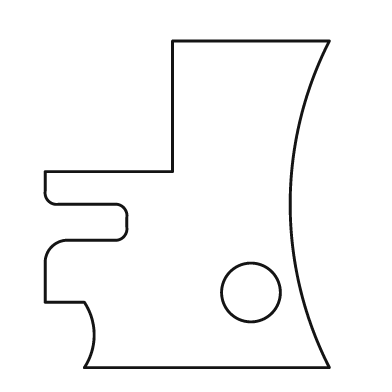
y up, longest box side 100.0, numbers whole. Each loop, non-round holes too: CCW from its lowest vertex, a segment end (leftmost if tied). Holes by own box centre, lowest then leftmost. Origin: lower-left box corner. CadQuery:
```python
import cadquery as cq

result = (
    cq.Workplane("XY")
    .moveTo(12.0, 0.0)
    .lineTo(87.0, 0.0)
    .threePointArc((75.0, 50.0), (87.0, 100.0))
    .lineTo(39.0, 100.0)
    .lineTo(39.0, 60.0)
    .lineTo(0.0, 60.0)
    .lineTo(0.0, 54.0)
    .threePointArc((1.0, 51.0), (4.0, 50.0))
    .lineTo(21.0, 50.0)
    .threePointArc((24.0, 49.0), (25.0, 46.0))
    .lineTo(25.0, 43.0)
    .threePointArc((24.0, 40.0), (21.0, 39.0))
    .lineTo(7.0, 39.0)
    .threePointArc((2.0, 37.0), (0.0, 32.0))
    .lineTo(0.0, 20.0)
    .lineTo(12.0, 20.0)
    .threePointArc((15.0, 10.0), (12.0, 0.0))
    .close()
    .moveTo(63.0, 23.0)
    .circle(9.0)
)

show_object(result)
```